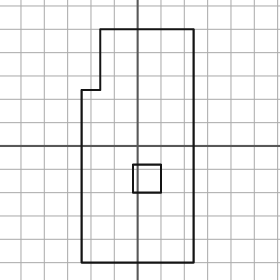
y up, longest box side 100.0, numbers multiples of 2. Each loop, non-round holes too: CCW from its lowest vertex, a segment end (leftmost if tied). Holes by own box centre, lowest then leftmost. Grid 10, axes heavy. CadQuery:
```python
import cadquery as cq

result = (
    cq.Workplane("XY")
    .moveTo(-24.0, -50.0)
    .lineTo(24.0, -50.0)
    .lineTo(24.0, 50.0)
    .lineTo(-16.0, 50.0)
    .lineTo(-16.0, 24.0)
    .lineTo(-24.0, 24.0)
    .close()
    .moveTo(-2.0, -20.0)
    .lineTo(10.0, -20.0)
    .lineTo(10.0, -8.0)
    .lineTo(-2.0, -8.0)
    .close()
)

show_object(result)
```